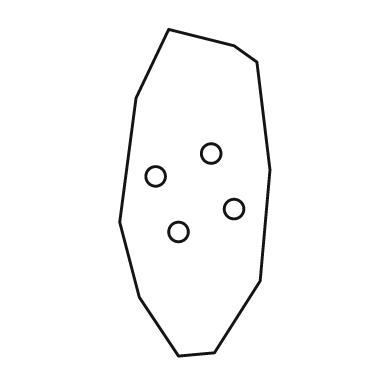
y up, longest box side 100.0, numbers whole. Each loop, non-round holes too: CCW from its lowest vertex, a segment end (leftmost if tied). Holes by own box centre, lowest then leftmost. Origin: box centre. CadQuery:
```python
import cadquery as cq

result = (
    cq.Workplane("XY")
    .moveTo(-5.0, -50.0)
    .lineTo(6.0, -49.0)
    .lineTo(20.0, -27.0)
    .lineTo(23.0, 7.0)
    .lineTo(19.0, 40.0)
    .lineTo(12.0, 45.0)
    .lineTo(-8.0, 50.0)
    .lineTo(-18.0, 29.0)
    .lineTo(-23.0, -9.0)
    .lineTo(-17.0, -32.0)
    .close()
    .moveTo(-5.0, -12.0)
    .circle(3.0)
    .moveTo(12.0, -5.0)
    .circle(3.0)
    .moveTo(-12.0, 5.0)
    .circle(3.0)
    .moveTo(5.0, 12.0)
    .circle(3.0)
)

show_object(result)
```